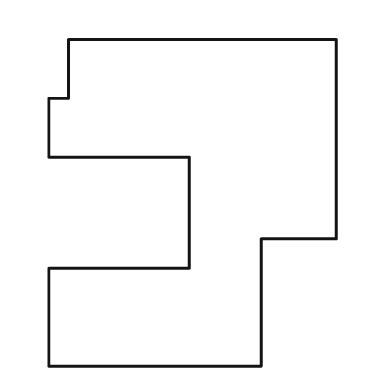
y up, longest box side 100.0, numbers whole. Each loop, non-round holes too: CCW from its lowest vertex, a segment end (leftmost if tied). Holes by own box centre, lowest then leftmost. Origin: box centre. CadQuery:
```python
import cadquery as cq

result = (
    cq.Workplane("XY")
    .moveTo(-44.0, -50.0)
    .lineTo(21.0, -50.0)
    .lineTo(21.0, -11.0)
    .lineTo(44.0, -11.0)
    .lineTo(44.0, 50.0)
    .lineTo(-38.0, 50.0)
    .lineTo(-38.0, 32.0)
    .lineTo(-44.0, 32.0)
    .lineTo(-44.0, 14.0)
    .lineTo(-1.0, 14.0)
    .lineTo(-1.0, -20.0)
    .lineTo(-44.0, -20.0)
    .close()
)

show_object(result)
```